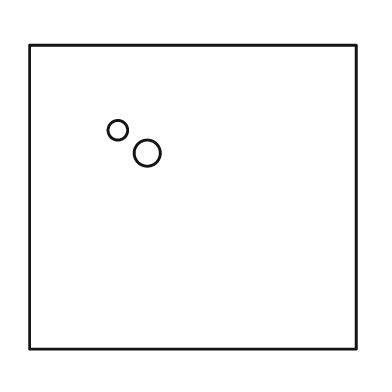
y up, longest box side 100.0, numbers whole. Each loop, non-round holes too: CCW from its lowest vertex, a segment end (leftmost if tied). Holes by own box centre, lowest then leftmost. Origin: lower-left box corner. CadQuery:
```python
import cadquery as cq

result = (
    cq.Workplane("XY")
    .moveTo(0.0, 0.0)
    .lineTo(100.0, 0.0)
    .lineTo(100.0, 93.0)
    .lineTo(0.0, 93.0)
    .close()
    .moveTo(36.0, 60.0)
    .circle(4.0)
    .moveTo(27.0, 67.0)
    .circle(3.0)
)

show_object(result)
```